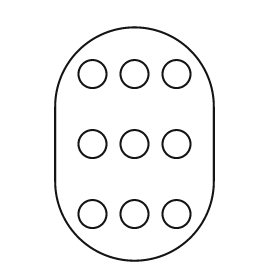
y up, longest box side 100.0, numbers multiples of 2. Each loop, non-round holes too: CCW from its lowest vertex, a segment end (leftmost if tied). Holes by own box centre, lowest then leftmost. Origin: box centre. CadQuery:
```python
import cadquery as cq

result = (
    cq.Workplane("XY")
    .moveTo(-34.0, -16.0)
    .threePointArc((0.0, -50.0), (34.0, -16.0))
    .lineTo(34.0, 16.0)
    .threePointArc((0.0, 50.0), (-34.0, 16.0))
    .close()
    .moveTo(-18.0, -30.0)
    .circle(6.0)
    .moveTo(0.0, -30.0)
    .circle(6.0)
    .moveTo(18.0, -30.0)
    .circle(6.0)
    .moveTo(-18.0, 0.0)
    .circle(6.0)
    .moveTo(0.0, 0.0)
    .circle(6.0)
    .moveTo(18.0, 0.0)
    .circle(6.0)
    .moveTo(-18.0, 30.0)
    .circle(6.0)
    .moveTo(0.0, 30.0)
    .circle(6.0)
    .moveTo(18.0, 30.0)
    .circle(6.0)
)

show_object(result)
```